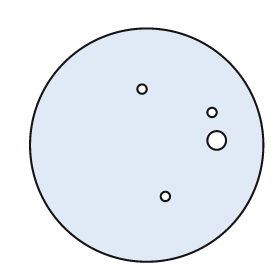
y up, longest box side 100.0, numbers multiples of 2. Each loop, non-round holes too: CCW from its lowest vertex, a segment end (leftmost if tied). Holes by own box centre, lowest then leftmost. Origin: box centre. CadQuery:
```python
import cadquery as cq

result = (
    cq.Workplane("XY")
    .moveTo(0.0, 0.0)
    .circle(50.0)
    .moveTo(8.0, -22.0)
    .circle(2.0)
    .moveTo(30.0, 2.0)
    .circle(4.0)
    .moveTo(28.0, 14.0)
    .circle(2.0)
    .moveTo(-2.0, 24.0)
    .circle(2.0)
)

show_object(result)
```